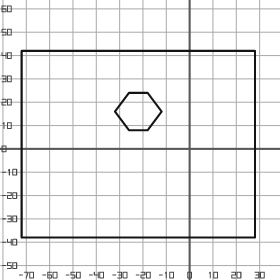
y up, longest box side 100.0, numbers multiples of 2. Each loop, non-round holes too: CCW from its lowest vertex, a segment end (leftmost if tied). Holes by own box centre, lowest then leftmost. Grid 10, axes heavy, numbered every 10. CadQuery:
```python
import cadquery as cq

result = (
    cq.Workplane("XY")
    .moveTo(-72.0, -38.0)
    .lineTo(28.0, -38.0)
    .lineTo(28.0, 42.0)
    .lineTo(-72.0, 42.0)
    .close()
    .moveTo(-26.0, 8.0)
    .lineTo(-18.0, 8.0)
    .lineTo(-12.0, 16.0)
    .lineTo(-18.0, 24.0)
    .lineTo(-26.0, 24.0)
    .lineTo(-32.0, 16.0)
    .close()
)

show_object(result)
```